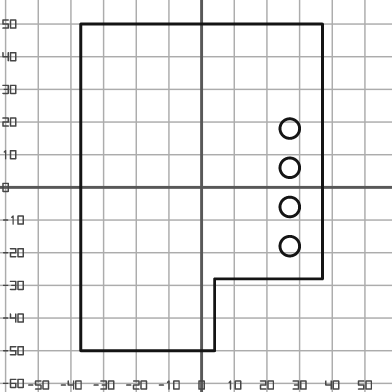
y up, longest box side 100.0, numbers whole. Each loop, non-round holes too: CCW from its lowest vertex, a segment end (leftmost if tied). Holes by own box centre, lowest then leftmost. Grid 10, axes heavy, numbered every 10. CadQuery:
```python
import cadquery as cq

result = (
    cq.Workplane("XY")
    .moveTo(-37.0, -50.0)
    .lineTo(4.0, -50.0)
    .lineTo(4.0, -28.0)
    .lineTo(37.0, -28.0)
    .lineTo(37.0, 50.0)
    .lineTo(-37.0, 50.0)
    .close()
    .moveTo(27.0, -18.0)
    .circle(3.0)
    .moveTo(27.0, -6.0)
    .circle(3.0)
    .moveTo(27.0, 6.0)
    .circle(3.0)
    .moveTo(27.0, 18.0)
    .circle(3.0)
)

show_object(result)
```